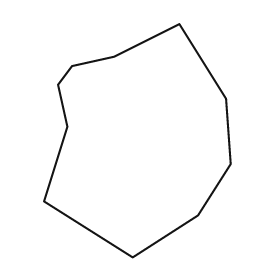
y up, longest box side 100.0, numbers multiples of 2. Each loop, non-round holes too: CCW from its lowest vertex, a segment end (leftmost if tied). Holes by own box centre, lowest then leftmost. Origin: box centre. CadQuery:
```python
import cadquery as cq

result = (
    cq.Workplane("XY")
    .moveTo(-2.0, -50.0)
    .lineTo(26.0, -32.0)
    .lineTo(40.0, -10.0)
    .lineTo(38.0, 18.0)
    .lineTo(18.0, 50.0)
    .lineTo(-10.0, 36.0)
    .lineTo(-28.0, 32.0)
    .lineTo(-34.0, 24.0)
    .lineTo(-30.0, 6.0)
    .lineTo(-40.0, -26.0)
    .close()
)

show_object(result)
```